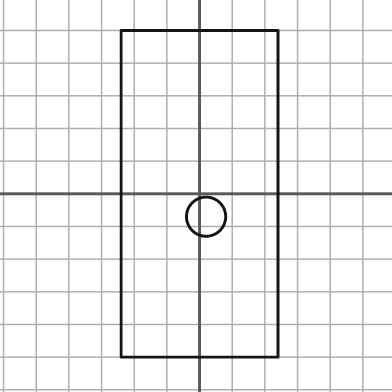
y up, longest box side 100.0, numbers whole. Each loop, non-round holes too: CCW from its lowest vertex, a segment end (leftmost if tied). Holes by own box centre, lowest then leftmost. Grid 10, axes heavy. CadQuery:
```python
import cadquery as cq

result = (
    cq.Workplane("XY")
    .moveTo(-24.0, -50.0)
    .lineTo(24.0, -50.0)
    .lineTo(24.0, 50.0)
    .lineTo(-24.0, 50.0)
    .close()
    .moveTo(2.0, -7.0)
    .circle(6.0)
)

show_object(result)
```